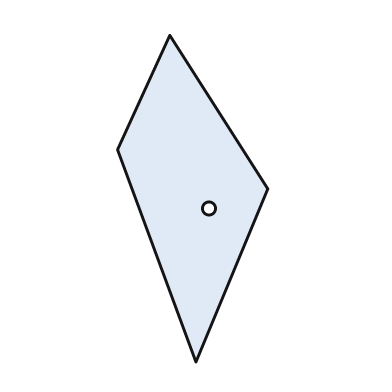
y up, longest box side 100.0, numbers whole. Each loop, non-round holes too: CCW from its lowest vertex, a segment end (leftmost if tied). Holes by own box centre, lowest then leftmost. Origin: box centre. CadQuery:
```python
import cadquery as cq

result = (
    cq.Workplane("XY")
    .moveTo(1.0, -50.0)
    .lineTo(23.0, 3.0)
    .lineTo(-7.0, 50.0)
    .lineTo(-23.0, 15.0)
    .close()
    .moveTo(5.0, -3.0)
    .circle(2.0)
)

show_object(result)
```